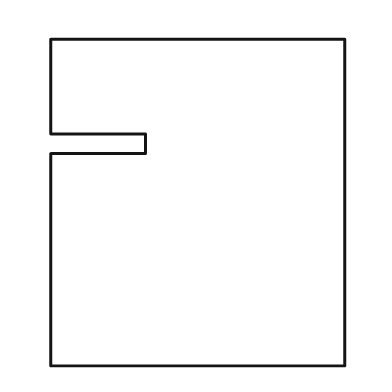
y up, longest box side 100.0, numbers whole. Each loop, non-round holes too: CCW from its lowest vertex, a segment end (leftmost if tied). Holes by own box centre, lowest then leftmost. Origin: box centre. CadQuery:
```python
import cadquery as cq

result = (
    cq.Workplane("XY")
    .moveTo(-45.0, -50.0)
    .lineTo(45.0, -50.0)
    .lineTo(45.0, 50.0)
    .lineTo(-45.0, 50.0)
    .lineTo(-45.0, 21.0)
    .lineTo(-16.0, 21.0)
    .lineTo(-16.0, 15.0)
    .lineTo(-45.0, 15.0)
    .close()
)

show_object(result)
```